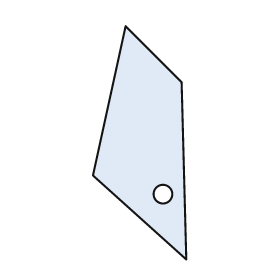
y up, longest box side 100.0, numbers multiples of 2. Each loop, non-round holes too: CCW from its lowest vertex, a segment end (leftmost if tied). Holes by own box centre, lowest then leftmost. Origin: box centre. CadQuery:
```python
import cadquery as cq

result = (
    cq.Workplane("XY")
    .moveTo(20.0, -50.0)
    .lineTo(18.0, 26.0)
    .lineTo(-6.0, 50.0)
    .lineTo(-20.0, -14.0)
    .close()
    .moveTo(10.0, -22.0)
    .circle(4.0)
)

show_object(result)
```